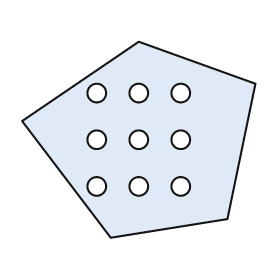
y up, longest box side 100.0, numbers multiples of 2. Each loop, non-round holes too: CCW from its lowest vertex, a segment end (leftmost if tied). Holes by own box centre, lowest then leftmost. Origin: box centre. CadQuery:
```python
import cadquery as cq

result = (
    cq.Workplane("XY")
    .moveTo(-12.0, -42.0)
    .lineTo(38.0, -34.0)
    .lineTo(50.0, 24.0)
    .lineTo(0.0, 42.0)
    .lineTo(-50.0, 8.0)
    .close()
    .moveTo(-18.0, -20.0)
    .circle(4.0)
    .moveTo(0.0, -20.0)
    .circle(4.0)
    .moveTo(18.0, -20.0)
    .circle(4.0)
    .moveTo(-18.0, 0.0)
    .circle(4.0)
    .moveTo(0.0, 0.0)
    .circle(4.0)
    .moveTo(18.0, 0.0)
    .circle(4.0)
    .moveTo(-18.0, 20.0)
    .circle(4.0)
    .moveTo(0.0, 20.0)
    .circle(4.0)
    .moveTo(18.0, 20.0)
    .circle(4.0)
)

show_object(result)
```